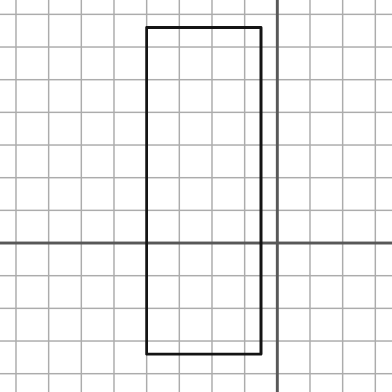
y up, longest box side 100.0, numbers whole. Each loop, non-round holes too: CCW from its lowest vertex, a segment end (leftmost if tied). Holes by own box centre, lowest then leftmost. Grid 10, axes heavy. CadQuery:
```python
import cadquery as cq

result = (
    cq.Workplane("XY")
    .moveTo(-40.0, -34.0)
    .lineTo(-5.0, -34.0)
    .lineTo(-5.0, 66.0)
    .lineTo(-40.0, 66.0)
    .close()
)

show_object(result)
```